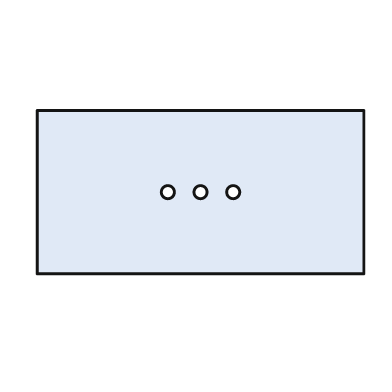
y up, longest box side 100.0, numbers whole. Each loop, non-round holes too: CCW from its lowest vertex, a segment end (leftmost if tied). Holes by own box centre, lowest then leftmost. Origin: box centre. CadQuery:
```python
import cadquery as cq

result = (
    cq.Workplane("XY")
    .moveTo(-50.0, -25.0)
    .lineTo(50.0, -25.0)
    .lineTo(50.0, 25.0)
    .lineTo(-50.0, 25.0)
    .close()
    .moveTo(-10.0, 0.0)
    .circle(2.0)
    .moveTo(0.0, 0.0)
    .circle(2.0)
    .moveTo(10.0, 0.0)
    .circle(2.0)
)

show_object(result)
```